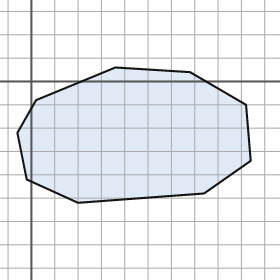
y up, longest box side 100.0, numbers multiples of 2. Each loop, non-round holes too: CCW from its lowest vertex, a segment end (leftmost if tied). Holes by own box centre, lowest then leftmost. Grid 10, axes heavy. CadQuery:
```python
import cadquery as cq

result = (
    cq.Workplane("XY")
    .moveTo(20.0, -52.0)
    .lineTo(74.0, -48.0)
    .lineTo(94.0, -34.0)
    .lineTo(92.0, -10.0)
    .lineTo(68.0, 4.0)
    .lineTo(36.0, 6.0)
    .lineTo(2.0, -8.0)
    .lineTo(-6.0, -22.0)
    .lineTo(-2.0, -42.0)
    .close()
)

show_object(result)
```